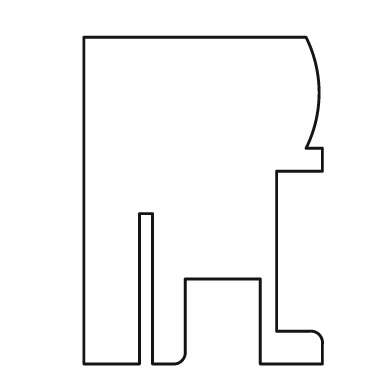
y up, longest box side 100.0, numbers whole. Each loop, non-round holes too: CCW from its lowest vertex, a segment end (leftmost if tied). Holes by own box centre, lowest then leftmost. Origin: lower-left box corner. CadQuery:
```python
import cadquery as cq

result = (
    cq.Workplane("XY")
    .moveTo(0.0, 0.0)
    .lineTo(17.0, 0.0)
    .lineTo(17.0, 46.0)
    .lineTo(21.0, 46.0)
    .lineTo(21.0, 0.0)
    .lineTo(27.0, 0.0)
    .threePointArc((30.0, 1.0), (31.0, 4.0))
    .lineTo(31.0, 26.0)
    .lineTo(54.0, 26.0)
    .lineTo(54.0, 0.0)
    .lineTo(73.0, 0.0)
    .lineTo(73.0, 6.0)
    .threePointArc((72.0, 9.0), (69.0, 10.0))
    .lineTo(59.0, 10.0)
    .lineTo(59.0, 59.0)
    .lineTo(73.0, 59.0)
    .lineTo(73.0, 66.0)
    .lineTo(68.0, 66.0)
    .threePointArc((72.0, 83.0), (68.0, 100.0))
    .lineTo(0.0, 100.0)
    .close()
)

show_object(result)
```